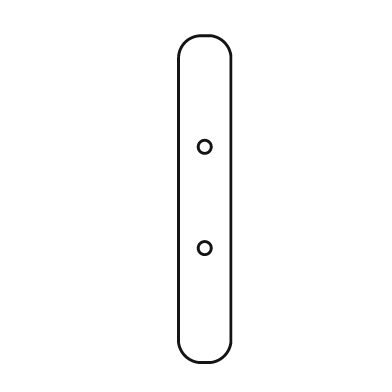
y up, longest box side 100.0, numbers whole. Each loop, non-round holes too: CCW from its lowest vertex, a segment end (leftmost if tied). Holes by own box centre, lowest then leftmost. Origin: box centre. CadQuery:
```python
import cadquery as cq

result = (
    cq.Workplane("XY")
    .moveTo(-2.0, -50.0)
    .lineTo(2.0, -50.0)
    .threePointArc((6.0, -48.0), (8.0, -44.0))
    .lineTo(8.0, 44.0)
    .threePointArc((6.0, 48.0), (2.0, 50.0))
    .lineTo(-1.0, 50.0)
    .threePointArc((-6.0, 48.0), (-8.0, 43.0))
    .lineTo(-8.0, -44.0)
    .threePointArc((-6.0, -48.0), (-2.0, -50.0))
    .close()
    .moveTo(0.0, -15.0)
    .circle(2.0)
    .moveTo(0.0, 16.0)
    .circle(2.0)
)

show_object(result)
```